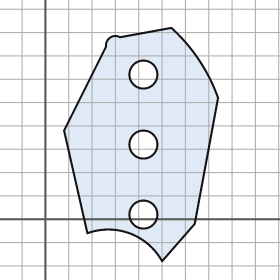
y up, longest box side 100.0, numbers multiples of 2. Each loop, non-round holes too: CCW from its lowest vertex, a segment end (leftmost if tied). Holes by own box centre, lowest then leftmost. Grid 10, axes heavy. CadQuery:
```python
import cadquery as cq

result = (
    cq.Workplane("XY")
    .moveTo(50.0, -18.0)
    .lineTo(64.0, -2.0)
    .lineTo(74.0, 52.0)
    .threePointArc((66.0, 68.0), (54.0, 82.0))
    .lineTo(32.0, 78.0)
    .threePointArc((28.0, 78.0), (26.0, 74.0))
    .lineTo(8.0, 38.0)
    .lineTo(18.0, -6.0)
    .threePointArc((36.0, -6.0), (50.0, -18.0))
    .close()
    .moveTo(42.0, 2.0)
    .circle(6.0)
    .moveTo(42.0, 32.0)
    .circle(6.0)
    .moveTo(42.0, 62.0)
    .circle(6.0)
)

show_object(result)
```